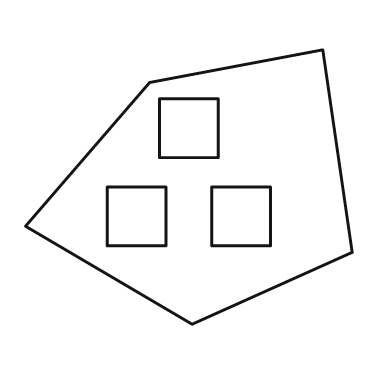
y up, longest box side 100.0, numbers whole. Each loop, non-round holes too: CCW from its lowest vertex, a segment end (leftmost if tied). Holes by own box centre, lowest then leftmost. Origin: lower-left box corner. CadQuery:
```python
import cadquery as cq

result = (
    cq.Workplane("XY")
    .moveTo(51.0, 0.0)
    .lineTo(100.0, 22.0)
    .lineTo(91.0, 84.0)
    .lineTo(38.0, 74.0)
    .lineTo(0.0, 30.0)
    .close()
    .moveTo(25.0, 24.0)
    .lineTo(43.0, 24.0)
    .lineTo(43.0, 42.0)
    .lineTo(25.0, 42.0)
    .close()
    .moveTo(57.0, 24.0)
    .lineTo(75.0, 24.0)
    .lineTo(75.0, 42.0)
    .lineTo(57.0, 42.0)
    .close()
    .moveTo(41.0, 51.0)
    .lineTo(59.0, 51.0)
    .lineTo(59.0, 69.0)
    .lineTo(41.0, 69.0)
    .close()
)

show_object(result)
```